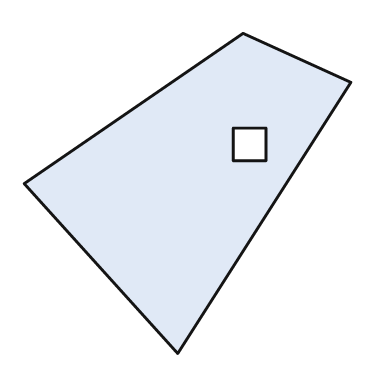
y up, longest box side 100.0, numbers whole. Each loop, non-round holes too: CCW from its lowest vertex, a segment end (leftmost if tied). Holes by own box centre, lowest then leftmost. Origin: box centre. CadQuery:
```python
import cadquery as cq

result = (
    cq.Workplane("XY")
    .moveTo(-3.0, -49.0)
    .lineTo(50.0, 34.0)
    .lineTo(17.0, 49.0)
    .lineTo(-50.0, 3.0)
    .close()
    .moveTo(14.0, 10.0)
    .lineTo(24.0, 10.0)
    .lineTo(24.0, 20.0)
    .lineTo(14.0, 20.0)
    .close()
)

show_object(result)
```